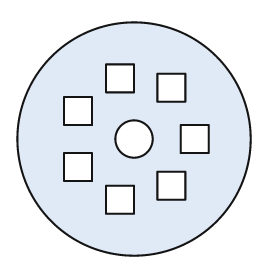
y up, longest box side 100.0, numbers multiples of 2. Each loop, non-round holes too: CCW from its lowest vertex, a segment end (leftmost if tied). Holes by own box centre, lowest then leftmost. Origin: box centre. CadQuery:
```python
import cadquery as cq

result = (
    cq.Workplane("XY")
    .moveTo(0.0, 0.0)
    .circle(50.0)
    .moveTo(-12.0, -32.0)
    .lineTo(0.0, -32.0)
    .lineTo(0.0, -20.0)
    .lineTo(-12.0, -20.0)
    .close()
    .moveTo(10.0, -26.0)
    .lineTo(22.0, -26.0)
    .lineTo(22.0, -14.0)
    .lineTo(10.0, -14.0)
    .close()
    .moveTo(-30.0, -18.0)
    .lineTo(-18.0, -18.0)
    .lineTo(-18.0, -6.0)
    .lineTo(-30.0, -6.0)
    .close()
    .moveTo(0.0, 0.0)
    .circle(8.0)
    .moveTo(20.0, -6.0)
    .lineTo(32.0, -6.0)
    .lineTo(32.0, 6.0)
    .lineTo(20.0, 6.0)
    .close()
    .moveTo(-30.0, 6.0)
    .lineTo(-18.0, 6.0)
    .lineTo(-18.0, 18.0)
    .lineTo(-30.0, 18.0)
    .close()
    .moveTo(10.0, 16.0)
    .lineTo(22.0, 16.0)
    .lineTo(22.0, 28.0)
    .lineTo(10.0, 28.0)
    .close()
    .moveTo(-12.0, 20.0)
    .lineTo(0.0, 20.0)
    .lineTo(0.0, 32.0)
    .lineTo(-12.0, 32.0)
    .close()
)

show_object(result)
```